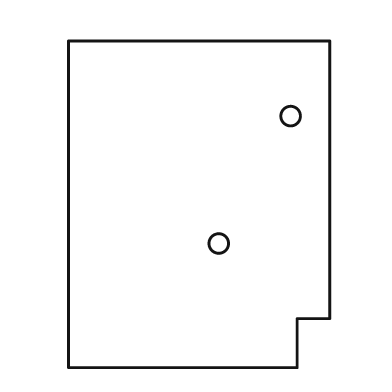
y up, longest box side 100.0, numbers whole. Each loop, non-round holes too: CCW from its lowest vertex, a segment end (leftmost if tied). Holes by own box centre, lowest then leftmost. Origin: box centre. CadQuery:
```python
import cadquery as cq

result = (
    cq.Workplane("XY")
    .moveTo(-40.0, -50.0)
    .lineTo(30.0, -50.0)
    .lineTo(30.0, -35.0)
    .lineTo(40.0, -35.0)
    .lineTo(40.0, 50.0)
    .lineTo(-40.0, 50.0)
    .close()
    .moveTo(6.0, -12.0)
    .circle(3.0)
    .moveTo(28.0, 27.0)
    .circle(3.0)
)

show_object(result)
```